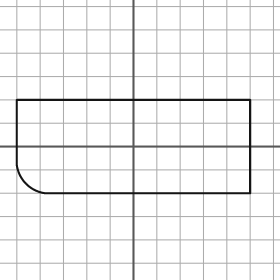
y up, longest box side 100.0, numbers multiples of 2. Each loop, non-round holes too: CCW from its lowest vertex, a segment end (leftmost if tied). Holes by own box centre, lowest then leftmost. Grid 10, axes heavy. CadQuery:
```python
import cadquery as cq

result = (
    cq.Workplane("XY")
    .moveTo(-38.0, -20.0)
    .lineTo(50.0, -20.0)
    .lineTo(50.0, 20.0)
    .lineTo(-50.0, 20.0)
    .lineTo(-50.0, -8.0)
    .threePointArc((-46.0, -16.0), (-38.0, -20.0))
    .close()
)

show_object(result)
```